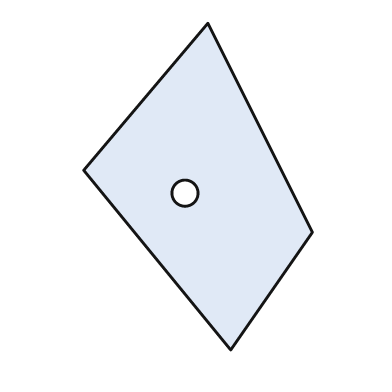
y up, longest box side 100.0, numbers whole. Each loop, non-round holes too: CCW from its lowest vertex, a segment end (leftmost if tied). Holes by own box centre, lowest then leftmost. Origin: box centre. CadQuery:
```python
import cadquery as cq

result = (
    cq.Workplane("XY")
    .moveTo(10.0, -50.0)
    .lineTo(35.0, -14.0)
    .lineTo(3.0, 50.0)
    .lineTo(-35.0, 5.0)
    .close()
    .moveTo(-4.0, -2.0)
    .circle(4.0)
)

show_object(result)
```